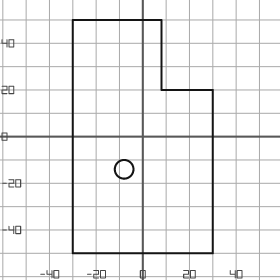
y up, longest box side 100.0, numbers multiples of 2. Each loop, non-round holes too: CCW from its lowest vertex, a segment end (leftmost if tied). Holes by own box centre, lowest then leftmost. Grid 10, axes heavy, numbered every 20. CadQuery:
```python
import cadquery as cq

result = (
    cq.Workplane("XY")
    .moveTo(-30.0, -50.0)
    .lineTo(30.0, -50.0)
    .lineTo(30.0, 20.0)
    .lineTo(8.0, 20.0)
    .lineTo(8.0, 50.0)
    .lineTo(-30.0, 50.0)
    .close()
    .moveTo(-8.0, -14.0)
    .circle(4.0)
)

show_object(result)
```